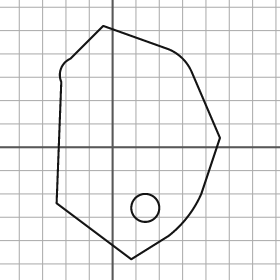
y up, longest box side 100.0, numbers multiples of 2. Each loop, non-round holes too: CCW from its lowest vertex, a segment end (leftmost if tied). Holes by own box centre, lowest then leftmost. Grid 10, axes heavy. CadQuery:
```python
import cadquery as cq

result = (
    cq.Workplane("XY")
    .moveTo(8.0, -48.0)
    .lineTo(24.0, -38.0)
    .threePointArc((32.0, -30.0), (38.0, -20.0))
    .lineTo(46.0, 4.0)
    .lineTo(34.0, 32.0)
    .threePointArc((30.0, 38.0), (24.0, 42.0))
    .lineTo(-4.0, 52.0)
    .lineTo(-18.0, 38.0)
    .threePointArc((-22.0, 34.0), (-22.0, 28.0))
    .lineTo(-24.0, -24.0)
    .close()
    .moveTo(14.0, -26.0)
    .circle(6.0)
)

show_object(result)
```